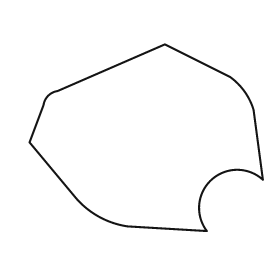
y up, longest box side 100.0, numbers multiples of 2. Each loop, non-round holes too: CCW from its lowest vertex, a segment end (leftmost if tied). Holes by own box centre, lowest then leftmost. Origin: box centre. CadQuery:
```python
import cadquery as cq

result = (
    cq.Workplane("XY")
    .moveTo(26.0, -40.0)
    .threePointArc((28.0, -18.0), (50.0, -18.0))
    .lineTo(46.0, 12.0)
    .threePointArc((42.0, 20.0), (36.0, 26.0))
    .lineTo(8.0, 40.0)
    .lineTo(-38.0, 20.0)
    .threePointArc((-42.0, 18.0), (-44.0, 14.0))
    .lineTo(-50.0, -2.0)
    .lineTo(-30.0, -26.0)
    .threePointArc((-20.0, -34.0), (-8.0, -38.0))
    .close()
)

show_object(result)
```